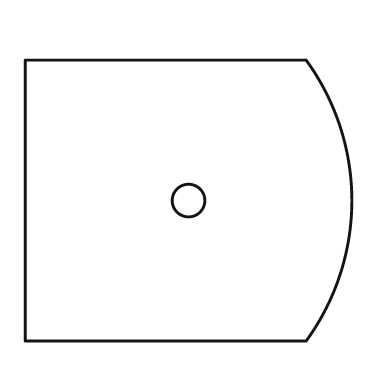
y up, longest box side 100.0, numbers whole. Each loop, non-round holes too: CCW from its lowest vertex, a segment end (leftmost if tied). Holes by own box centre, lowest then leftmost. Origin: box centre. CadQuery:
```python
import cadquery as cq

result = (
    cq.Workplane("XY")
    .moveTo(-50.0, -43.0)
    .lineTo(36.0, -43.0)
    .threePointArc((50.0, 0.0), (36.0, 43.0))
    .lineTo(-50.0, 43.0)
    .close()
    .moveTo(0.0, 0.0)
    .circle(5.0)
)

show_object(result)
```